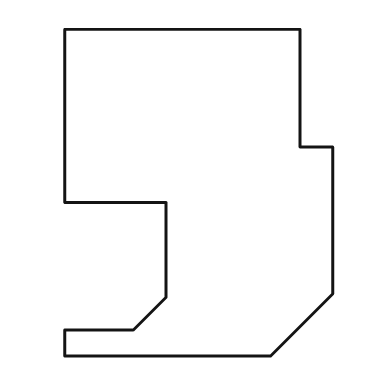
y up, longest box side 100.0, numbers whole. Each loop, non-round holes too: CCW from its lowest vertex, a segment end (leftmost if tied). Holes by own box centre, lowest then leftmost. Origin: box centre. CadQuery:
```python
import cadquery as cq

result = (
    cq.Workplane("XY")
    .moveTo(-41.0, -50.0)
    .lineTo(22.0, -50.0)
    .lineTo(41.0, -31.0)
    .lineTo(41.0, 14.0)
    .lineTo(31.0, 14.0)
    .lineTo(31.0, 50.0)
    .lineTo(-41.0, 50.0)
    .lineTo(-41.0, -3.0)
    .lineTo(-10.0, -3.0)
    .lineTo(-10.0, -32.0)
    .lineTo(-20.0, -42.0)
    .lineTo(-41.0, -42.0)
    .close()
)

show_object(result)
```